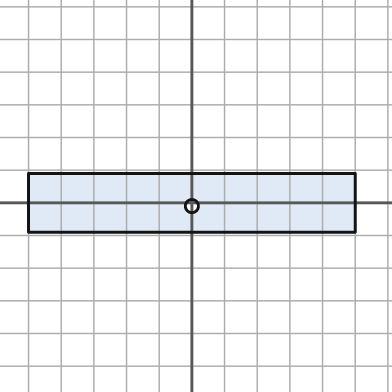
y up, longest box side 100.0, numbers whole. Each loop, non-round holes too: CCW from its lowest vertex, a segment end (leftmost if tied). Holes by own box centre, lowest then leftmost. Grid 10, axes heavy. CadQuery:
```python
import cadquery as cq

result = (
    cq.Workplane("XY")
    .moveTo(-50.0, -9.0)
    .lineTo(50.0, -9.0)
    .lineTo(50.0, 9.0)
    .lineTo(-50.0, 9.0)
    .close()
    .moveTo(0.0, -1.0)
    .circle(2.0)
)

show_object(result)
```